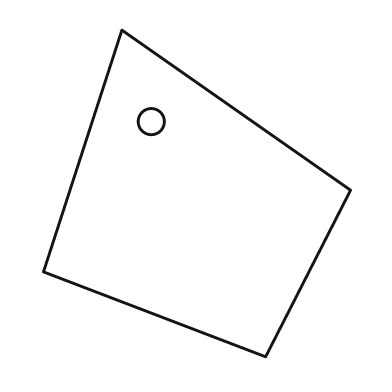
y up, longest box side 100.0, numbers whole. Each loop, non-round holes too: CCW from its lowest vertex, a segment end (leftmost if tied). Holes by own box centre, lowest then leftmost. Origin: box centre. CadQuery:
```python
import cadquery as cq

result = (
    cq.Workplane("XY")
    .moveTo(21.0, -50.0)
    .lineTo(47.0, 1.0)
    .lineTo(-23.0, 50.0)
    .lineTo(-47.0, -24.0)
    .close()
    .moveTo(-14.0, 22.0)
    .circle(4.0)
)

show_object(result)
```